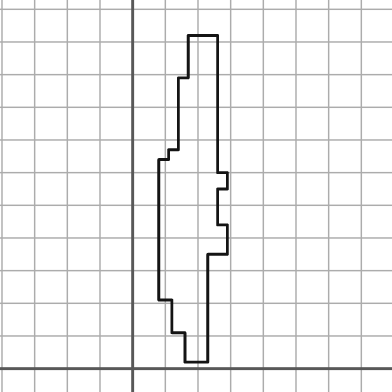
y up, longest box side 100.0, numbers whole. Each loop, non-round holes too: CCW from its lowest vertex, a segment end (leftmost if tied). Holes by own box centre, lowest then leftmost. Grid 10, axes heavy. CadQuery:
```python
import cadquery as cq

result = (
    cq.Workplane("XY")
    .moveTo(16.0, 2.0)
    .lineTo(23.0, 2.0)
    .lineTo(23.0, 35.0)
    .lineTo(29.0, 35.0)
    .lineTo(29.0, 44.0)
    .lineTo(26.0, 44.0)
    .lineTo(26.0, 55.0)
    .lineTo(29.0, 55.0)
    .lineTo(29.0, 60.0)
    .lineTo(26.0, 60.0)
    .lineTo(26.0, 102.0)
    .lineTo(17.0, 102.0)
    .lineTo(17.0, 89.0)
    .lineTo(14.0, 89.0)
    .lineTo(14.0, 67.0)
    .lineTo(11.0, 67.0)
    .lineTo(11.0, 64.0)
    .lineTo(8.0, 64.0)
    .lineTo(8.0, 21.0)
    .lineTo(12.0, 21.0)
    .lineTo(12.0, 11.0)
    .lineTo(16.0, 11.0)
    .close()
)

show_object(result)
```